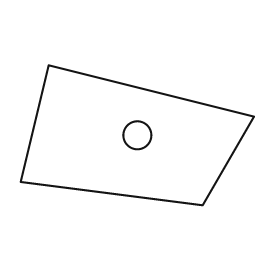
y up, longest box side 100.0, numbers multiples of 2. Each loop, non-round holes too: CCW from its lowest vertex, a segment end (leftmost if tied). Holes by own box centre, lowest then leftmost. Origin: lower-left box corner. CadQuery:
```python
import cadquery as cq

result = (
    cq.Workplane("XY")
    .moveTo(78.0, 0.0)
    .lineTo(100.0, 38.0)
    .lineTo(12.0, 60.0)
    .lineTo(0.0, 10.0)
    .close()
    .moveTo(50.0, 30.0)
    .circle(6.0)
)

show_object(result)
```